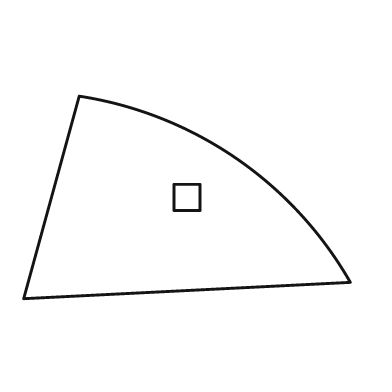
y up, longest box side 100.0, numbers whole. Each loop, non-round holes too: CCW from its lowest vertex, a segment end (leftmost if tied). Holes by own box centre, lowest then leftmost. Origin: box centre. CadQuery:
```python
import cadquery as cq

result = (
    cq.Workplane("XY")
    .moveTo(-50.0, -31.0)
    .lineTo(50.0, -26.0)
    .threePointArc((15.0, 12.0), (-33.0, 31.0))
    .close()
    .moveTo(-4.0, -4.0)
    .lineTo(4.0, -4.0)
    .lineTo(4.0, 4.0)
    .lineTo(-4.0, 4.0)
    .close()
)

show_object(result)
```